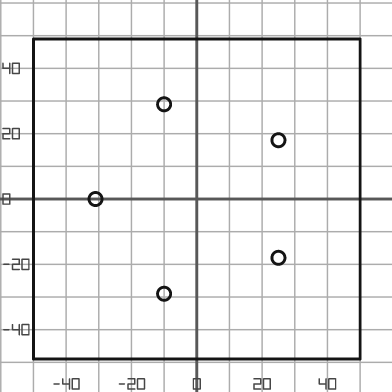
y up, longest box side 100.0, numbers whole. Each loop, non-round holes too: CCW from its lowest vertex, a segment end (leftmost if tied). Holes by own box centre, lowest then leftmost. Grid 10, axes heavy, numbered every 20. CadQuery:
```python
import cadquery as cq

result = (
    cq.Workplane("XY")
    .moveTo(-50.0, -49.0)
    .lineTo(50.0, -49.0)
    .lineTo(50.0, 49.0)
    .lineTo(-50.0, 49.0)
    .close()
    .moveTo(-10.0, -29.0)
    .circle(2.0)
    .moveTo(25.0, -18.0)
    .circle(2.0)
    .moveTo(-31.0, 0.0)
    .circle(2.0)
    .moveTo(25.0, 18.0)
    .circle(2.0)
    .moveTo(-10.0, 29.0)
    .circle(2.0)
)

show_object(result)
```